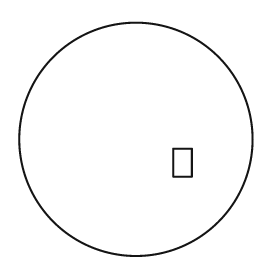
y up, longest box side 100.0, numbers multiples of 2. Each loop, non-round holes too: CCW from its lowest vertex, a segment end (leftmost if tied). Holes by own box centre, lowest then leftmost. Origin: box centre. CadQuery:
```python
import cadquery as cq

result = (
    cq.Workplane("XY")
    .moveTo(0.0, 0.0)
    .circle(50.0)
    .moveTo(16.0, -16.0)
    .lineTo(24.0, -16.0)
    .lineTo(24.0, -4.0)
    .lineTo(16.0, -4.0)
    .close()
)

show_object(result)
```